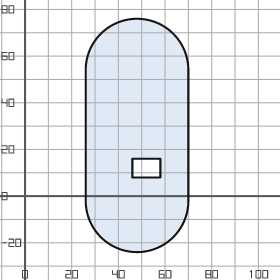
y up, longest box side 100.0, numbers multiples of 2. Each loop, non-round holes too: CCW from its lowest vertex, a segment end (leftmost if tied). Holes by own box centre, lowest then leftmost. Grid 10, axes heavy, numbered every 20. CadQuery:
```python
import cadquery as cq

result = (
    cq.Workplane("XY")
    .moveTo(26.0, -2.0)
    .threePointArc((48.0, -24.0), (70.0, -2.0))
    .lineTo(70.0, 54.0)
    .threePointArc((48.0, 76.0), (26.0, 54.0))
    .close()
    .moveTo(46.0, 8.0)
    .lineTo(58.0, 8.0)
    .lineTo(58.0, 16.0)
    .lineTo(46.0, 16.0)
    .close()
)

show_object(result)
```